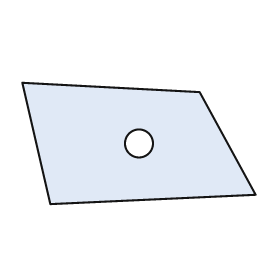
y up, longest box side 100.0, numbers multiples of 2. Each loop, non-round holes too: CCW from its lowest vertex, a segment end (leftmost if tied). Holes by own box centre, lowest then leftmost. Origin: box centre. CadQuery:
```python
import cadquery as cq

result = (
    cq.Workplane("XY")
    .moveTo(-38.0, -26.0)
    .lineTo(50.0, -22.0)
    .lineTo(26.0, 22.0)
    .lineTo(-50.0, 26.0)
    .close()
    .moveTo(0.0, 0.0)
    .circle(6.0)
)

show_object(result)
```